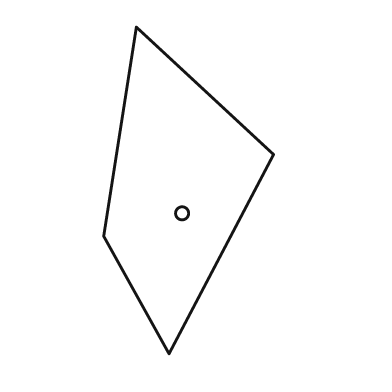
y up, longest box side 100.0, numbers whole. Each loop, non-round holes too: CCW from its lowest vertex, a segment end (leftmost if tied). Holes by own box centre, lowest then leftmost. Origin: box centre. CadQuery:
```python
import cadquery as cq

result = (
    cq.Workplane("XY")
    .moveTo(-6.0, -50.0)
    .lineTo(26.0, 11.0)
    .lineTo(-16.0, 50.0)
    .lineTo(-26.0, -14.0)
    .close()
    .moveTo(-2.0, -7.0)
    .circle(2.0)
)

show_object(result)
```